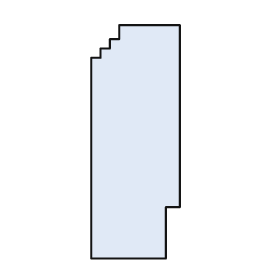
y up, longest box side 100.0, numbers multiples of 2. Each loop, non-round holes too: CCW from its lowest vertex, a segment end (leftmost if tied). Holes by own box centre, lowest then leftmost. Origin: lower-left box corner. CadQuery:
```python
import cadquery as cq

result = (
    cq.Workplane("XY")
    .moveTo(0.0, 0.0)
    .lineTo(32.0, 0.0)
    .lineTo(32.0, 22.0)
    .lineTo(38.0, 22.0)
    .lineTo(38.0, 100.0)
    .lineTo(12.0, 100.0)
    .lineTo(12.0, 94.0)
    .lineTo(8.0, 94.0)
    .lineTo(8.0, 90.0)
    .lineTo(4.0, 90.0)
    .lineTo(4.0, 86.0)
    .lineTo(0.0, 86.0)
    .close()
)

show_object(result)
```